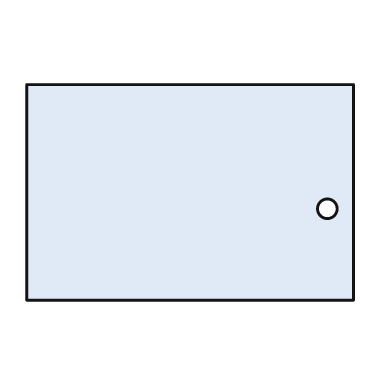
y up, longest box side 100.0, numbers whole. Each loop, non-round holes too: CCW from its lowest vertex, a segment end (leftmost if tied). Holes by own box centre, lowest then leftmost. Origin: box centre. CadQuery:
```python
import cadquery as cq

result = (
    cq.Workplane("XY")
    .moveTo(-50.0, -33.0)
    .lineTo(50.0, -33.0)
    .lineTo(50.0, 33.0)
    .lineTo(-50.0, 33.0)
    .close()
    .moveTo(42.0, -5.0)
    .circle(3.0)
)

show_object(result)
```